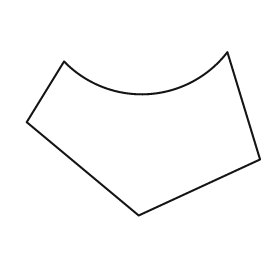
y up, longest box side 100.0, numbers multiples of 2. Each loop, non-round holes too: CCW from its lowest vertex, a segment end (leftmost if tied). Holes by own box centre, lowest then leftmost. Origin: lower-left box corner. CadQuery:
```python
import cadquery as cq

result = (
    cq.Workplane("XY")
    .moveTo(48.0, 0.0)
    .lineTo(100.0, 24.0)
    .lineTo(86.0, 70.0)
    .threePointArc((52.0, 52.0), (16.0, 66.0))
    .lineTo(0.0, 40.0)
    .close()
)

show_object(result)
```